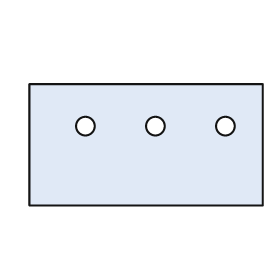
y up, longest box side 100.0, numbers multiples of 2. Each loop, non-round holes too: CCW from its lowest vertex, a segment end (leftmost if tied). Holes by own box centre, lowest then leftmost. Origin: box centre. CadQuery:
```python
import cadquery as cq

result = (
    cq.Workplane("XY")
    .moveTo(-50.0, -26.0)
    .lineTo(50.0, -26.0)
    .lineTo(50.0, 26.0)
    .lineTo(-50.0, 26.0)
    .close()
    .moveTo(-26.0, 8.0)
    .circle(4.0)
    .moveTo(4.0, 8.0)
    .circle(4.0)
    .moveTo(34.0, 8.0)
    .circle(4.0)
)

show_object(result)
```